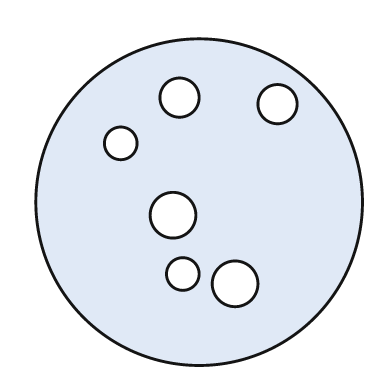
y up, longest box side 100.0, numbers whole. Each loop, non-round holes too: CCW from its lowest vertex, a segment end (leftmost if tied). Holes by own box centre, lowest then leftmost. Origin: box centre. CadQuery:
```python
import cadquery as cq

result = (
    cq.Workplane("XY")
    .moveTo(0.0, 0.0)
    .circle(50.0)
    .moveTo(11.0, -25.0)
    .circle(7.0)
    .moveTo(-5.0, -22.0)
    .circle(5.0)
    .moveTo(-8.0, -4.0)
    .circle(7.0)
    .moveTo(-24.0, 18.0)
    .circle(5.0)
    .moveTo(24.0, 30.0)
    .circle(6.0)
    .moveTo(-6.0, 32.0)
    .circle(6.0)
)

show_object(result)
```